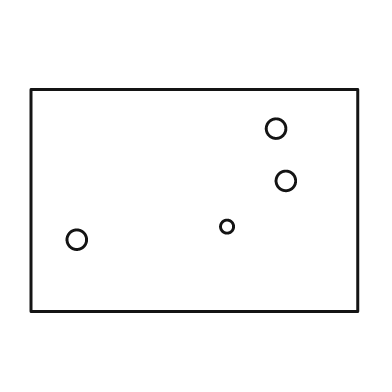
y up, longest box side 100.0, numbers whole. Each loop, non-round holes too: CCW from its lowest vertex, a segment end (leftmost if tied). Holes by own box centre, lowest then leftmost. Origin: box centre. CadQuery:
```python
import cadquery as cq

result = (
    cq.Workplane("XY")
    .moveTo(-50.0, -34.0)
    .lineTo(50.0, -34.0)
    .lineTo(50.0, 34.0)
    .lineTo(-50.0, 34.0)
    .close()
    .moveTo(-36.0, -12.0)
    .circle(3.0)
    .moveTo(10.0, -8.0)
    .circle(2.0)
    .moveTo(28.0, 6.0)
    .circle(3.0)
    .moveTo(25.0, 22.0)
    .circle(3.0)
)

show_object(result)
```